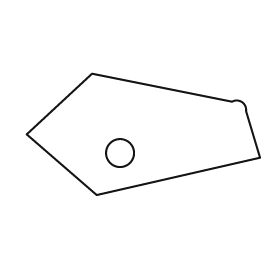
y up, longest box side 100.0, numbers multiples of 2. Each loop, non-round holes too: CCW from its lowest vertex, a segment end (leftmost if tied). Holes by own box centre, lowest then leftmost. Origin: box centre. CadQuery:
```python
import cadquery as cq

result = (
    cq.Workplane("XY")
    .moveTo(-20.0, -26.0)
    .lineTo(50.0, -10.0)
    .lineTo(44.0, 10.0)
    .threePointArc((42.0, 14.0), (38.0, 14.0))
    .lineTo(-22.0, 26.0)
    .lineTo(-50.0, 0.0)
    .close()
    .moveTo(-10.0, -8.0)
    .circle(6.0)
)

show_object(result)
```